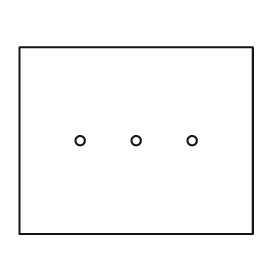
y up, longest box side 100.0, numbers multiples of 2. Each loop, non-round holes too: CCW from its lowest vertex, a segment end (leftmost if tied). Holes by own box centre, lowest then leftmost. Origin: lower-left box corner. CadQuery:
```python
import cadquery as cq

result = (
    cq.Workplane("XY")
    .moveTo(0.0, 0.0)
    .lineTo(100.0, 0.0)
    .lineTo(100.0, 80.0)
    .lineTo(0.0, 80.0)
    .close()
    .moveTo(26.0, 40.0)
    .circle(2.0)
    .moveTo(50.0, 40.0)
    .circle(2.0)
    .moveTo(74.0, 40.0)
    .circle(2.0)
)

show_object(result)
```